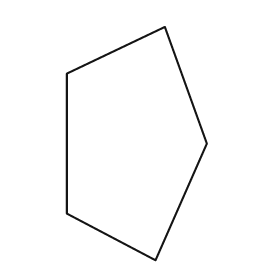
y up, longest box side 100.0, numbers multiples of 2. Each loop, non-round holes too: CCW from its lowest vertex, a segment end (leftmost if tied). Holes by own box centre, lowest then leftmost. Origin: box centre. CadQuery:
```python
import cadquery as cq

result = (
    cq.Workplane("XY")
    .moveTo(8.0, -50.0)
    .lineTo(30.0, 0.0)
    .lineTo(12.0, 50.0)
    .lineTo(-30.0, 30.0)
    .lineTo(-30.0, -30.0)
    .close()
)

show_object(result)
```